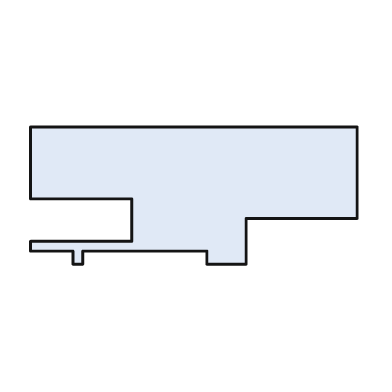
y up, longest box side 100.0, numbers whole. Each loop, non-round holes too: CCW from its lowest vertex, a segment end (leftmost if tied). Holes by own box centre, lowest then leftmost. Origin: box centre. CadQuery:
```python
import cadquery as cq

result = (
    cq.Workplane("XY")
    .moveTo(-37.0, -21.0)
    .lineTo(-34.0, -21.0)
    .lineTo(-34.0, -17.0)
    .lineTo(4.0, -17.0)
    .lineTo(4.0, -21.0)
    .lineTo(16.0, -21.0)
    .lineTo(16.0, -7.0)
    .lineTo(50.0, -7.0)
    .lineTo(50.0, 21.0)
    .lineTo(-50.0, 21.0)
    .lineTo(-50.0, -1.0)
    .lineTo(-19.0, -1.0)
    .lineTo(-19.0, -14.0)
    .lineTo(-50.0, -14.0)
    .lineTo(-50.0, -17.0)
    .lineTo(-37.0, -17.0)
    .close()
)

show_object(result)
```